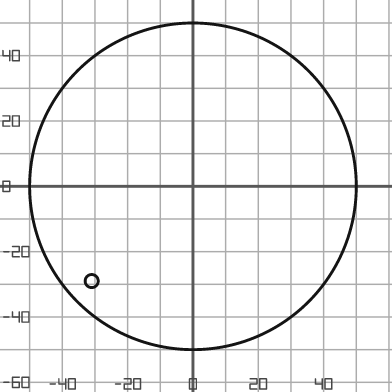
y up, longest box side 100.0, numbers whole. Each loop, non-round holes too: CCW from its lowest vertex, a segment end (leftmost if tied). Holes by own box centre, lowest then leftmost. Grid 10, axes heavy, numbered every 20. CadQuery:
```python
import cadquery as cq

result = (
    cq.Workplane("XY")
    .moveTo(0.0, 0.0)
    .circle(50.0)
    .moveTo(-31.0, -29.0)
    .circle(2.0)
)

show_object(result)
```